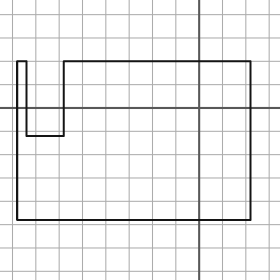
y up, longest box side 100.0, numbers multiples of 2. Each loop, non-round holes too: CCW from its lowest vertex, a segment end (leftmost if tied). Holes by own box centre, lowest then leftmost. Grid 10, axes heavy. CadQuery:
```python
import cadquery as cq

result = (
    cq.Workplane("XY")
    .moveTo(-78.0, -48.0)
    .lineTo(22.0, -48.0)
    .lineTo(22.0, 20.0)
    .lineTo(-58.0, 20.0)
    .lineTo(-58.0, -12.0)
    .lineTo(-74.0, -12.0)
    .lineTo(-74.0, 20.0)
    .lineTo(-78.0, 20.0)
    .close()
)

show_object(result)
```